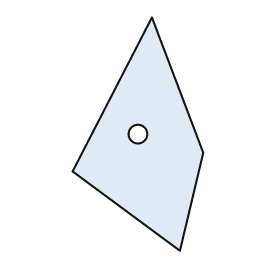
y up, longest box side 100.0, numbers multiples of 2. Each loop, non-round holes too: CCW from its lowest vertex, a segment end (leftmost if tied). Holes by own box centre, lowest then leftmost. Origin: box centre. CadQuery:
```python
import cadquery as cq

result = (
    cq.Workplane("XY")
    .moveTo(18.0, -50.0)
    .lineTo(28.0, -8.0)
    .lineTo(6.0, 50.0)
    .lineTo(-28.0, -16.0)
    .close()
    .moveTo(0.0, 0.0)
    .circle(4.0)
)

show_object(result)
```